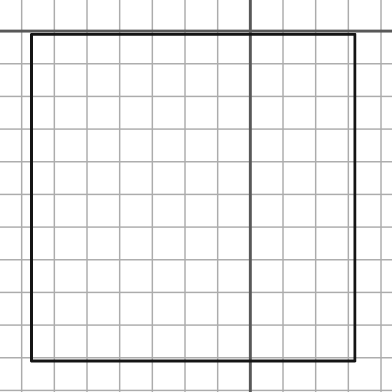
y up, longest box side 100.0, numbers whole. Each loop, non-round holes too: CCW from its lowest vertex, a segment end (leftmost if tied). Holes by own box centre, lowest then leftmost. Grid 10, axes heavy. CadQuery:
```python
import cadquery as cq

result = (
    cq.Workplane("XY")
    .moveTo(-67.0, -101.0)
    .lineTo(32.0, -101.0)
    .lineTo(32.0, -1.0)
    .lineTo(-67.0, -1.0)
    .close()
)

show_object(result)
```